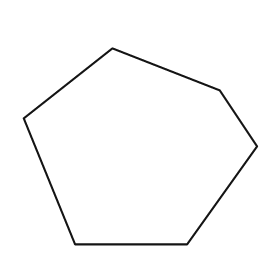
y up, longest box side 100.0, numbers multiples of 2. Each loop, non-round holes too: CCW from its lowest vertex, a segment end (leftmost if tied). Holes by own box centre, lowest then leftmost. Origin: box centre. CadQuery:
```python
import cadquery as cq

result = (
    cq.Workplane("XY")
    .moveTo(-28.0, -42.0)
    .lineTo(20.0, -42.0)
    .lineTo(50.0, 0.0)
    .lineTo(34.0, 24.0)
    .lineTo(-12.0, 42.0)
    .lineTo(-50.0, 12.0)
    .close()
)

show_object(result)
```